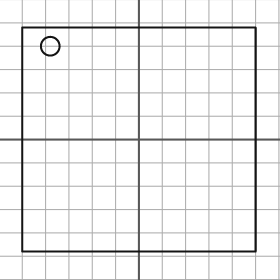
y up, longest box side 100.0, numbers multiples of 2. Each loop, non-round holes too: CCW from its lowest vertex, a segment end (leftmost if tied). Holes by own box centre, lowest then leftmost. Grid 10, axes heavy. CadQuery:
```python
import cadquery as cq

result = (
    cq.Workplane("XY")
    .moveTo(-50.0, -48.0)
    .lineTo(50.0, -48.0)
    .lineTo(50.0, 48.0)
    .lineTo(-50.0, 48.0)
    .close()
    .moveTo(-38.0, 40.0)
    .circle(4.0)
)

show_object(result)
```